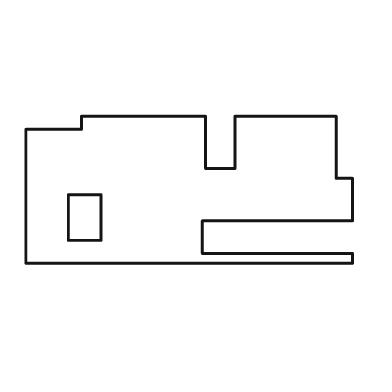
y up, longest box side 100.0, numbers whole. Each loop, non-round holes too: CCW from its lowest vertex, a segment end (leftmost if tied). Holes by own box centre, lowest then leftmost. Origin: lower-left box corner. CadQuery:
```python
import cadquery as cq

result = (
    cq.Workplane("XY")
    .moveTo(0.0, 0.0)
    .lineTo(100.0, 0.0)
    .lineTo(100.0, 3.0)
    .lineTo(54.0, 3.0)
    .lineTo(54.0, 13.0)
    .lineTo(100.0, 13.0)
    .lineTo(100.0, 26.0)
    .lineTo(95.0, 26.0)
    .lineTo(95.0, 45.0)
    .lineTo(64.0, 45.0)
    .lineTo(64.0, 29.0)
    .lineTo(55.0, 29.0)
    .lineTo(55.0, 45.0)
    .lineTo(17.0, 45.0)
    .lineTo(17.0, 41.0)
    .lineTo(0.0, 41.0)
    .close()
    .moveTo(13.0, 7.0)
    .lineTo(23.0, 7.0)
    .lineTo(23.0, 21.0)
    .lineTo(13.0, 21.0)
    .close()
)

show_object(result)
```